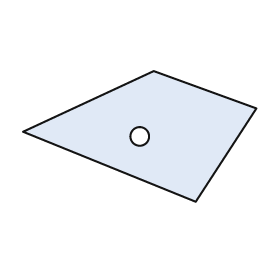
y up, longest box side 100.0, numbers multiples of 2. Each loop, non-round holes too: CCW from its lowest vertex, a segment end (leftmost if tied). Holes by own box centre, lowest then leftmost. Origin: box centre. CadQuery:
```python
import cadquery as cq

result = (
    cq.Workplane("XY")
    .moveTo(24.0, -28.0)
    .lineTo(50.0, 12.0)
    .lineTo(6.0, 28.0)
    .lineTo(-50.0, 2.0)
    .close()
    .moveTo(0.0, 0.0)
    .circle(4.0)
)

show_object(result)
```